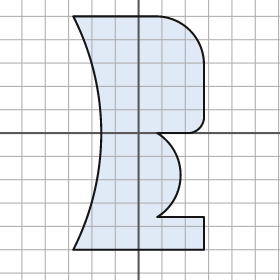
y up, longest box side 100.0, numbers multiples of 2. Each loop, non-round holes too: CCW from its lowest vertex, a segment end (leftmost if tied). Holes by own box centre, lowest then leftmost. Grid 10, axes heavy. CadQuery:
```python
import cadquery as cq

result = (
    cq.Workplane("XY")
    .moveTo(-28.0, -50.0)
    .lineTo(28.0, -50.0)
    .lineTo(28.0, -36.0)
    .lineTo(8.0, -36.0)
    .threePointArc((18.0, -18.0), (8.0, 0.0))
    .lineTo(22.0, 0.0)
    .threePointArc((26.0, 2.0), (28.0, 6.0))
    .lineTo(28.0, 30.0)
    .threePointArc((22.0, 44.0), (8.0, 50.0))
    .lineTo(-28.0, 50.0)
    .threePointArc((-16.0, 0.0), (-28.0, -50.0))
    .close()
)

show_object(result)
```